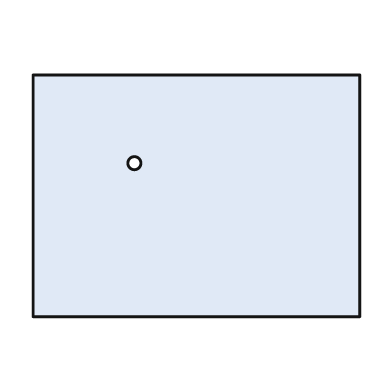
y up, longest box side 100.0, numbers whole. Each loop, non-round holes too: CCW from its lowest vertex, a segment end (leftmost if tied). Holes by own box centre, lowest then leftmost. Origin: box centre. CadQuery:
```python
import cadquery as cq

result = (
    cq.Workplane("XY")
    .moveTo(-50.0, -37.0)
    .lineTo(50.0, -37.0)
    .lineTo(50.0, 37.0)
    .lineTo(-50.0, 37.0)
    .close()
    .moveTo(-19.0, 10.0)
    .circle(2.0)
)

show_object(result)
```